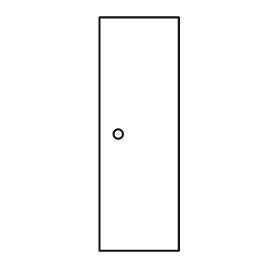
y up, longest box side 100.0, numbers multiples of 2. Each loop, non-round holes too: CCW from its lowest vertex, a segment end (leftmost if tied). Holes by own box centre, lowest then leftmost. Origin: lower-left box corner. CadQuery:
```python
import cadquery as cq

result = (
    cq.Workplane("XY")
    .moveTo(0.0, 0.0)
    .lineTo(34.0, 0.0)
    .lineTo(34.0, 100.0)
    .lineTo(0.0, 100.0)
    .close()
    .moveTo(8.0, 50.0)
    .circle(2.0)
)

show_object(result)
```